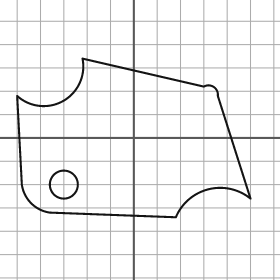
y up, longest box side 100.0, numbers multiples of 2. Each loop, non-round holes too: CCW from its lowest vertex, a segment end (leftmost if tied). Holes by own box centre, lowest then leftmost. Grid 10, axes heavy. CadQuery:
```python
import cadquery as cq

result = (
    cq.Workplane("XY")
    .moveTo(18.0, -34.0)
    .threePointArc((32.0, -22.0), (50.0, -26.0))
    .lineTo(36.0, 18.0)
    .threePointArc((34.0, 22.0), (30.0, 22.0))
    .lineTo(-22.0, 34.0)
    .threePointArc((-30.0, 16.0), (-50.0, 18.0))
    .lineTo(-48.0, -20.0)
    .threePointArc((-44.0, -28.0), (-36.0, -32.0))
    .close()
    .moveTo(-30.0, -20.0)
    .circle(6.0)
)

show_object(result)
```